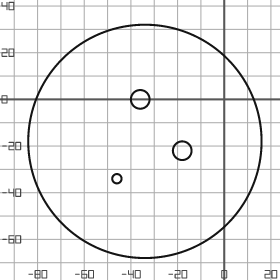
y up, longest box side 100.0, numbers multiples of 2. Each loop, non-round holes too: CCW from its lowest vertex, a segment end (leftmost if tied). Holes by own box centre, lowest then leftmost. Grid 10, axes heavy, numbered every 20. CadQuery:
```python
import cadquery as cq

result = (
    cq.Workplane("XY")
    .moveTo(-34.0, -18.0)
    .circle(50.0)
    .moveTo(-46.0, -34.0)
    .circle(2.0)
    .moveTo(-18.0, -22.0)
    .circle(4.0)
    .moveTo(-36.0, 0.0)
    .circle(4.0)
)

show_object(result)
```